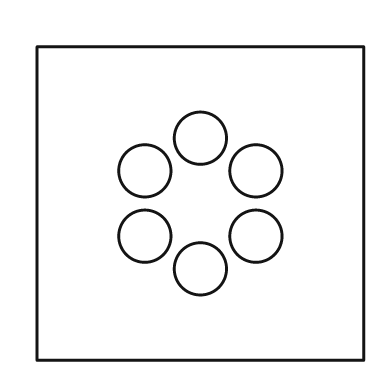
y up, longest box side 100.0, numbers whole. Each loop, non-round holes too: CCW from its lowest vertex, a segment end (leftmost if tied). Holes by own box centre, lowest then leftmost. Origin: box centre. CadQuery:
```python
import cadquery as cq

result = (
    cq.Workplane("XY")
    .moveTo(-50.0, -48.0)
    .lineTo(50.0, -48.0)
    .lineTo(50.0, 48.0)
    .lineTo(-50.0, 48.0)
    .close()
    .moveTo(0.0, -20.0)
    .circle(8.0)
    .moveTo(-17.0, -10.0)
    .circle(8.0)
    .moveTo(17.0, -10.0)
    .circle(8.0)
    .moveTo(-17.0, 10.0)
    .circle(8.0)
    .moveTo(17.0, 10.0)
    .circle(8.0)
    .moveTo(0.0, 20.0)
    .circle(8.0)
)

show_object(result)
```